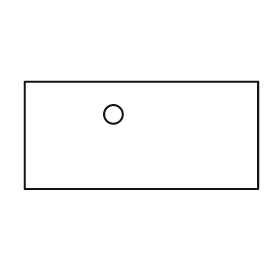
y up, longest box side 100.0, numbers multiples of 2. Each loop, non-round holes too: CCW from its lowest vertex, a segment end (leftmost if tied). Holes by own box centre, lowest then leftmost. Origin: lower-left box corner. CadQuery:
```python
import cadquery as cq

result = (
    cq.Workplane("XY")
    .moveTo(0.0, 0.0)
    .lineTo(100.0, 0.0)
    .lineTo(100.0, 46.0)
    .lineTo(0.0, 46.0)
    .close()
    .moveTo(38.0, 32.0)
    .circle(4.0)
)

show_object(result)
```